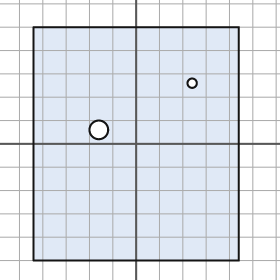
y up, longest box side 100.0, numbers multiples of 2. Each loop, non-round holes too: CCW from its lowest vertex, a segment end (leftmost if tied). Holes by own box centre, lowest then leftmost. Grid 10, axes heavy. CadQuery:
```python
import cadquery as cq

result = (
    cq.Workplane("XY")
    .moveTo(-44.0, -50.0)
    .lineTo(44.0, -50.0)
    .lineTo(44.0, 50.0)
    .lineTo(-44.0, 50.0)
    .close()
    .moveTo(-16.0, 6.0)
    .circle(4.0)
    .moveTo(24.0, 26.0)
    .circle(2.0)
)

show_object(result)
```